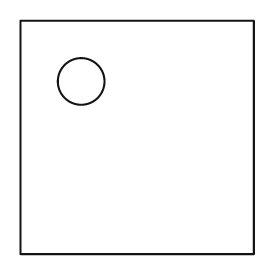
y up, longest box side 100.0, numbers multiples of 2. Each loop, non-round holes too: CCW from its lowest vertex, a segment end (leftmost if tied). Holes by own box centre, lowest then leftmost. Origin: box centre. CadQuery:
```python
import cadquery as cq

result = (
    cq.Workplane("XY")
    .moveTo(-50.0, -50.0)
    .lineTo(50.0, -50.0)
    .lineTo(50.0, 50.0)
    .lineTo(-50.0, 50.0)
    .close()
    .moveTo(-24.0, 24.0)
    .circle(10.0)
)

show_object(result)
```